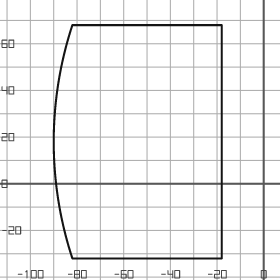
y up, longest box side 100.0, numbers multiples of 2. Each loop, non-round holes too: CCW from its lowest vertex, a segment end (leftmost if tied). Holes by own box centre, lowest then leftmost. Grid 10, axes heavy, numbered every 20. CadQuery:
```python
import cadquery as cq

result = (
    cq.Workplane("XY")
    .moveTo(-82.0, -32.0)
    .lineTo(-18.0, -32.0)
    .lineTo(-18.0, 68.0)
    .lineTo(-82.0, 68.0)
    .threePointArc((-90.0, 18.0), (-82.0, -32.0))
    .close()
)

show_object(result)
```